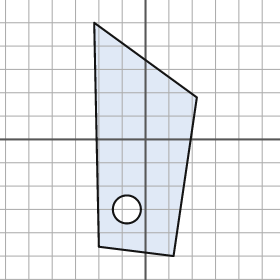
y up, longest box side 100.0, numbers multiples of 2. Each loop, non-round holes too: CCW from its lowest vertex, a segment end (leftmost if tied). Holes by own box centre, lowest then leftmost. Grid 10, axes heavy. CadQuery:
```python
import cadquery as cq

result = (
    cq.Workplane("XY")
    .moveTo(12.0, -50.0)
    .lineTo(22.0, 18.0)
    .lineTo(-22.0, 50.0)
    .lineTo(-20.0, -46.0)
    .close()
    .moveTo(-8.0, -30.0)
    .circle(6.0)
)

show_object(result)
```